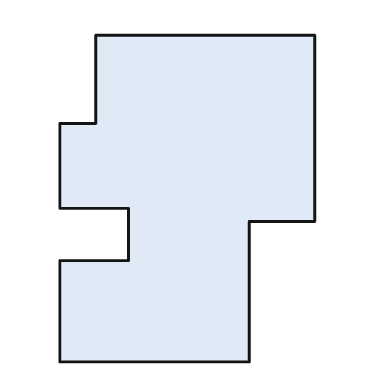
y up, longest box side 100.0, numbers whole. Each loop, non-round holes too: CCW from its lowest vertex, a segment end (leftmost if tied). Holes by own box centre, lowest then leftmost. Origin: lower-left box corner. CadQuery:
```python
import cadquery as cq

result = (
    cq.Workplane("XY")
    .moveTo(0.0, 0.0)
    .lineTo(58.0, 0.0)
    .lineTo(58.0, 43.0)
    .lineTo(78.0, 43.0)
    .lineTo(78.0, 100.0)
    .lineTo(11.0, 100.0)
    .lineTo(11.0, 73.0)
    .lineTo(0.0, 73.0)
    .lineTo(0.0, 47.0)
    .lineTo(21.0, 47.0)
    .lineTo(21.0, 31.0)
    .lineTo(0.0, 31.0)
    .close()
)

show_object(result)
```